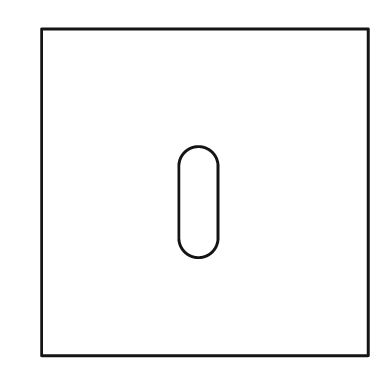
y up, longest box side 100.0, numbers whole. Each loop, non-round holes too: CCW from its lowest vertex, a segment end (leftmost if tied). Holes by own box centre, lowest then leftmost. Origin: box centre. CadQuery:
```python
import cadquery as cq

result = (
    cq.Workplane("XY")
    .moveTo(-50.0, -50.0)
    .lineTo(50.0, -50.0)
    .lineTo(50.0, 50.0)
    .lineTo(-50.0, 50.0)
    .close()
    .moveTo(-8.0, -14.0)
    .threePointArc((-2.0, -20.0), (4.0, -14.0))
    .lineTo(4.0, 8.0)
    .threePointArc((-2.0, 14.0), (-8.0, 8.0))
    .close()
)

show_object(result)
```